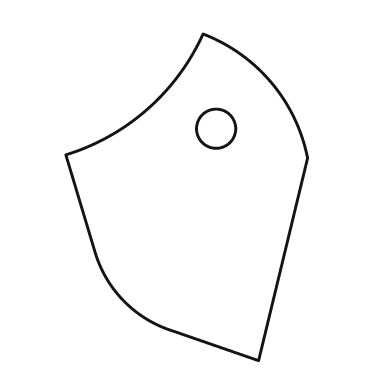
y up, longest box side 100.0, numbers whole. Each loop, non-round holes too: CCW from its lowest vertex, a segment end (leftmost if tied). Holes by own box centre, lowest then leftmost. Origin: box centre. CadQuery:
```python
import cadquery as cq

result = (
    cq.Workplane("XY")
    .moveTo(22.0, -50.0)
    .lineTo(37.0, 12.0)
    .threePointArc((26.0, 35.0), (5.0, 50.0))
    .threePointArc((-12.0, 27.0), (-37.0, 13.0))
    .lineTo(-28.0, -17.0)
    .threePointArc((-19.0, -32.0), (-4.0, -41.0))
    .close()
    .moveTo(9.0, 21.0)
    .circle(6.0)
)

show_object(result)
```